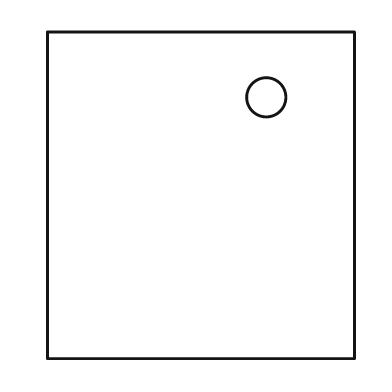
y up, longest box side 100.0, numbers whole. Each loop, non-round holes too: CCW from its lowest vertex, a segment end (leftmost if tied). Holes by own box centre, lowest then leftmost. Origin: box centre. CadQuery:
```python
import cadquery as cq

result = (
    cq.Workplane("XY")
    .moveTo(-47.0, -50.0)
    .lineTo(47.0, -50.0)
    .lineTo(47.0, 50.0)
    .lineTo(-47.0, 50.0)
    .close()
    .moveTo(20.0, 30.0)
    .circle(6.0)
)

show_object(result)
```